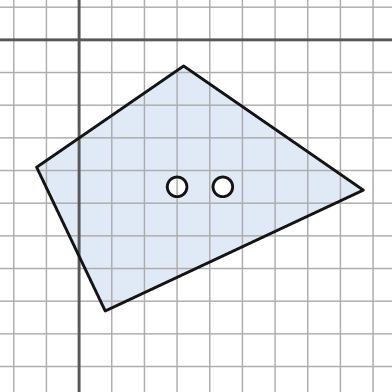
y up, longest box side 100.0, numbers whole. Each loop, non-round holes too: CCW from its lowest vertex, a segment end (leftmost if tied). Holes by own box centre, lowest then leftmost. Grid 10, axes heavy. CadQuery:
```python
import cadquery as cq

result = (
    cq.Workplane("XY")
    .moveTo(8.0, -83.0)
    .lineTo(87.0, -46.0)
    .lineTo(32.0, -8.0)
    .lineTo(-13.0, -39.0)
    .close()
    .moveTo(30.0, -45.0)
    .circle(3.0)
    .moveTo(44.0, -45.0)
    .circle(3.0)
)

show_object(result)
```